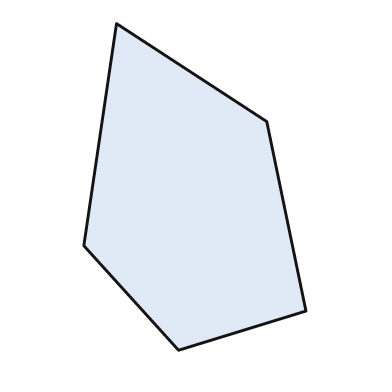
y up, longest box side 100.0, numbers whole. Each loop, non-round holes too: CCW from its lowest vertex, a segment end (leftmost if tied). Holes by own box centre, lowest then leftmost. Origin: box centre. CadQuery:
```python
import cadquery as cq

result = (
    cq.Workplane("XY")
    .moveTo(-5.0, -50.0)
    .lineTo(34.0, -38.0)
    .lineTo(22.0, 20.0)
    .lineTo(-24.0, 50.0)
    .lineTo(-34.0, -18.0)
    .close()
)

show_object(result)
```